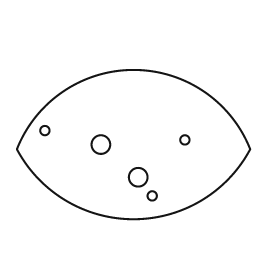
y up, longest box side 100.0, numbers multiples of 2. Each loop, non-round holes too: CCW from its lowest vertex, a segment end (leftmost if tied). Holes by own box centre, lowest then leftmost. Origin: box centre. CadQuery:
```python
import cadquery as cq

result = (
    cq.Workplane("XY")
    .moveTo(-50.0, -2.0)
    .threePointArc((0.0, -32.0), (50.0, -2.0))
    .threePointArc((0.0, 32.0), (-50.0, -2.0))
    .close()
    .moveTo(8.0, -22.0)
    .circle(2.0)
    .moveTo(2.0, -14.0)
    .circle(4.0)
    .moveTo(-14.0, 0.0)
    .circle(4.0)
    .moveTo(22.0, 2.0)
    .circle(2.0)
    .moveTo(-38.0, 6.0)
    .circle(2.0)
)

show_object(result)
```